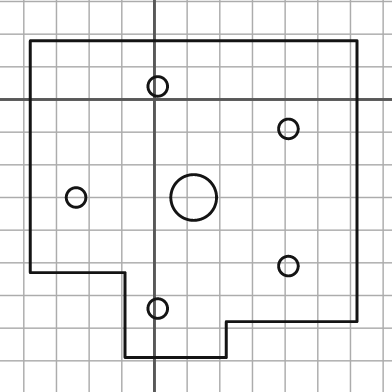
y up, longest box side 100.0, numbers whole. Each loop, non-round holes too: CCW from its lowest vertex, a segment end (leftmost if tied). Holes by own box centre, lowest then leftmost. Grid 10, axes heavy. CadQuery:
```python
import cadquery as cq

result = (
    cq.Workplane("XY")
    .moveTo(-9.0, -79.0)
    .lineTo(22.0, -79.0)
    .lineTo(22.0, -68.0)
    .lineTo(62.0, -68.0)
    .lineTo(62.0, 18.0)
    .lineTo(-38.0, 18.0)
    .lineTo(-38.0, -53.0)
    .lineTo(-9.0, -53.0)
    .close()
    .moveTo(1.0, -64.0)
    .circle(3.0)
    .moveTo(41.0, -51.0)
    .circle(3.0)
    .moveTo(-24.0, -30.0)
    .circle(3.0)
    .moveTo(12.0, -30.0)
    .circle(7.0)
    .moveTo(41.0, -9.0)
    .circle(3.0)
    .moveTo(1.0, 4.0)
    .circle(3.0)
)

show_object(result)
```